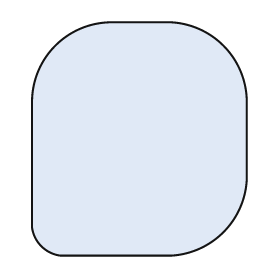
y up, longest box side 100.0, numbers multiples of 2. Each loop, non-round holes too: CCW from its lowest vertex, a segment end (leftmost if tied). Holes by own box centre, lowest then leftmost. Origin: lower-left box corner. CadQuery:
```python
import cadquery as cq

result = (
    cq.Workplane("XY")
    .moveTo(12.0, 0.0)
    .lineTo(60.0, 0.0)
    .threePointArc((82.0, 10.0), (92.0, 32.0))
    .lineTo(92.0, 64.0)
    .threePointArc((82.0, 90.0), (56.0, 100.0))
    .lineTo(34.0, 100.0)
    .threePointArc((10.0, 90.0), (0.0, 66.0))
    .lineTo(0.0, 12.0)
    .threePointArc((4.0, 4.0), (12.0, 0.0))
    .close()
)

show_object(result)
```